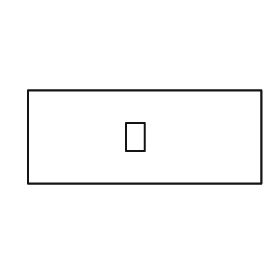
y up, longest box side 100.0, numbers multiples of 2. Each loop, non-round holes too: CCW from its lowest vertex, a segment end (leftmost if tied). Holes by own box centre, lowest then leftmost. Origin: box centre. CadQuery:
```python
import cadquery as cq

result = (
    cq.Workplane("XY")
    .moveTo(-50.0, -20.0)
    .lineTo(50.0, -20.0)
    .lineTo(50.0, 20.0)
    .lineTo(-50.0, 20.0)
    .close()
    .moveTo(-8.0, -6.0)
    .lineTo(0.0, -6.0)
    .lineTo(0.0, 6.0)
    .lineTo(-8.0, 6.0)
    .close()
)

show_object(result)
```